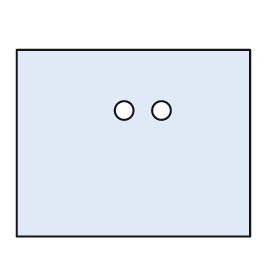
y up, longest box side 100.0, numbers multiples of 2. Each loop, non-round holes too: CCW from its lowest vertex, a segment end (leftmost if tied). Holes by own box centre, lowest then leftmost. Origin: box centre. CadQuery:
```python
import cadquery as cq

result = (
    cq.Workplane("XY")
    .moveTo(-50.0, -40.0)
    .lineTo(50.0, -40.0)
    .lineTo(50.0, 40.0)
    .lineTo(-50.0, 40.0)
    .close()
    .moveTo(-4.0, 14.0)
    .circle(4.0)
    .moveTo(12.0, 14.0)
    .circle(4.0)
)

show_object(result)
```